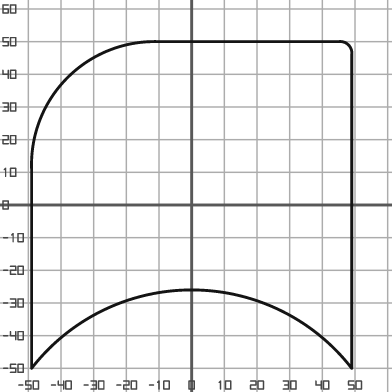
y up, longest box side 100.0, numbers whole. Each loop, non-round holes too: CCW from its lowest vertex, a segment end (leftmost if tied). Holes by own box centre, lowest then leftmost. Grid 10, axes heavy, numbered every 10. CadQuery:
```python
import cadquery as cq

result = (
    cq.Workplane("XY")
    .moveTo(-49.0, -50.0)
    .threePointArc((0.0, -26.0), (49.0, -50.0))
    .lineTo(49.0, 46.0)
    .threePointArc((48.0, 49.0), (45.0, 50.0))
    .lineTo(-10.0, 50.0)
    .threePointArc((-38.0, 39.0), (-49.0, 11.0))
    .close()
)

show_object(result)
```